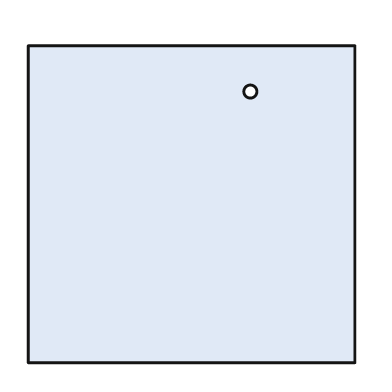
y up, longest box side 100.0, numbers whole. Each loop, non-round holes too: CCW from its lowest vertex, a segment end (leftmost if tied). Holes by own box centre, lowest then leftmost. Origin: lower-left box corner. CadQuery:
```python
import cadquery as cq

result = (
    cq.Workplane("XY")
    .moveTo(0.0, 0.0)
    .lineTo(100.0, 0.0)
    .lineTo(100.0, 97.0)
    .lineTo(0.0, 97.0)
    .close()
    .moveTo(68.0, 83.0)
    .circle(2.0)
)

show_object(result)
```